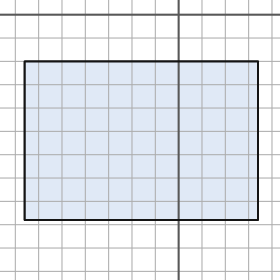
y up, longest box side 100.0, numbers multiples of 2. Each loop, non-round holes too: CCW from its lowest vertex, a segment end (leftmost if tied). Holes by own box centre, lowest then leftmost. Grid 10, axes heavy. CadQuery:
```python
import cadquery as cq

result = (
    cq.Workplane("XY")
    .moveTo(-66.0, -88.0)
    .lineTo(34.0, -88.0)
    .lineTo(34.0, -20.0)
    .lineTo(-66.0, -20.0)
    .close()
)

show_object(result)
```